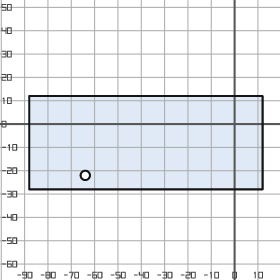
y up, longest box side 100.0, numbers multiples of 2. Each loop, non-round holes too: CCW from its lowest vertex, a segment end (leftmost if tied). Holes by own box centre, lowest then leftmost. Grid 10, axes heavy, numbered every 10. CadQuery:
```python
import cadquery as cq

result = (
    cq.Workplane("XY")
    .moveTo(-88.0, -28.0)
    .lineTo(12.0, -28.0)
    .lineTo(12.0, 12.0)
    .lineTo(-88.0, 12.0)
    .close()
    .moveTo(-64.0, -22.0)
    .circle(2.0)
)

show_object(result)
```